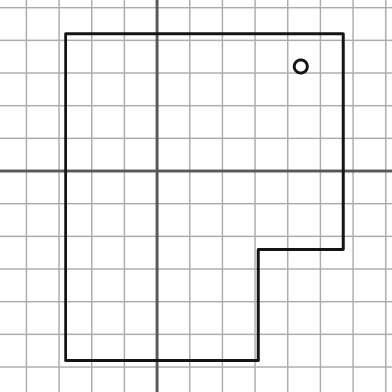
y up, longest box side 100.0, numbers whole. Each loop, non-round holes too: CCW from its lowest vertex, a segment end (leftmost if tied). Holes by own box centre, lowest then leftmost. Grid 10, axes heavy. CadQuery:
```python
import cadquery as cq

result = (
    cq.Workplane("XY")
    .moveTo(-28.0, -58.0)
    .lineTo(31.0, -58.0)
    .lineTo(31.0, -24.0)
    .lineTo(57.0, -24.0)
    .lineTo(57.0, 42.0)
    .lineTo(-28.0, 42.0)
    .close()
    .moveTo(44.0, 32.0)
    .circle(2.0)
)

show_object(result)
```